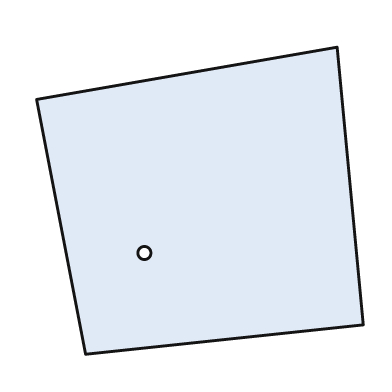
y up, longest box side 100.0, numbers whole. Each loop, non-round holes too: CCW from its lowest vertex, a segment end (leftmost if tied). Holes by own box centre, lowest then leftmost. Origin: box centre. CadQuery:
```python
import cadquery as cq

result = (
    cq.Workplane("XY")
    .moveTo(-35.0, -47.0)
    .lineTo(50.0, -38.0)
    .lineTo(42.0, 47.0)
    .lineTo(-50.0, 31.0)
    .close()
    .moveTo(-17.0, -16.0)
    .circle(2.0)
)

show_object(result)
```